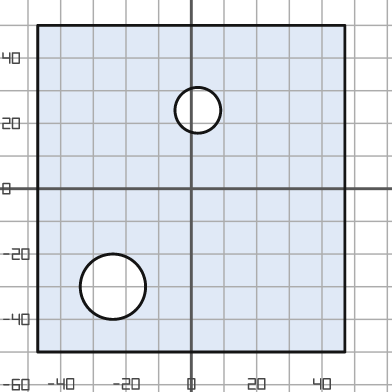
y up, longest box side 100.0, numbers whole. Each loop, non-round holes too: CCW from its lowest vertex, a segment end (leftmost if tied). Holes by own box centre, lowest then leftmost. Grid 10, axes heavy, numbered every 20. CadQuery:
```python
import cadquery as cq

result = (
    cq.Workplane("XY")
    .moveTo(-47.0, -50.0)
    .lineTo(47.0, -50.0)
    .lineTo(47.0, 50.0)
    .lineTo(-47.0, 50.0)
    .close()
    .moveTo(-24.0, -30.0)
    .circle(10.0)
    .moveTo(2.0, 24.0)
    .circle(7.0)
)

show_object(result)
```